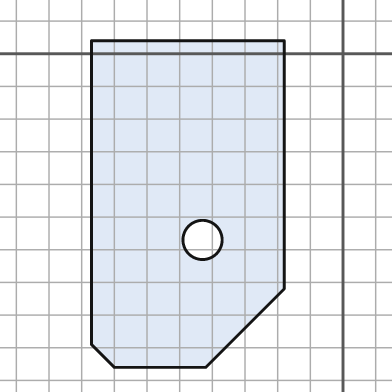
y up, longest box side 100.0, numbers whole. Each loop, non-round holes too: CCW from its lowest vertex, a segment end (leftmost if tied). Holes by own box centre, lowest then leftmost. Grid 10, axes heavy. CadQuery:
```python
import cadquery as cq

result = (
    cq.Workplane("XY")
    .moveTo(-70.0, -96.0)
    .lineTo(-42.0, -96.0)
    .lineTo(-18.0, -72.0)
    .lineTo(-18.0, 4.0)
    .lineTo(-77.0, 4.0)
    .lineTo(-77.0, -89.0)
    .close()
    .moveTo(-43.0, -57.0)
    .circle(6.0)
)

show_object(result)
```